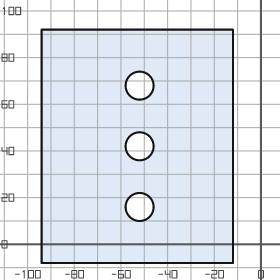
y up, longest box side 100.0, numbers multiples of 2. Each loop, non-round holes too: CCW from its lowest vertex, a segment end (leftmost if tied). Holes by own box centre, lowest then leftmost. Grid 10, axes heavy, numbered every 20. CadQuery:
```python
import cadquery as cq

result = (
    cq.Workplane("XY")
    .moveTo(-94.0, -8.0)
    .lineTo(-12.0, -8.0)
    .lineTo(-12.0, 92.0)
    .lineTo(-94.0, 92.0)
    .close()
    .moveTo(-52.0, 16.0)
    .circle(6.0)
    .moveTo(-52.0, 42.0)
    .circle(6.0)
    .moveTo(-52.0, 68.0)
    .circle(6.0)
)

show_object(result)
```